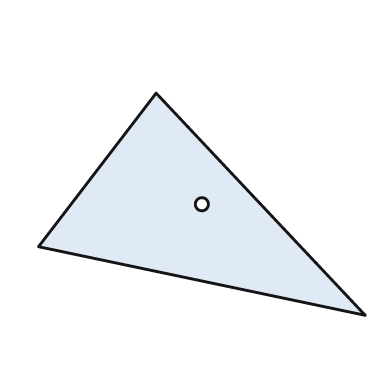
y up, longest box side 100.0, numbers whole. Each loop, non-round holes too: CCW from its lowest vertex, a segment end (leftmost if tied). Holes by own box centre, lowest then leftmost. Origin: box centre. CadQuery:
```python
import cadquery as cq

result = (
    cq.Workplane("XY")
    .moveTo(50.0, -34.0)
    .lineTo(-14.0, 34.0)
    .lineTo(-50.0, -13.0)
    .close()
    .moveTo(0.0, 0.0)
    .circle(2.0)
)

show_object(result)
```